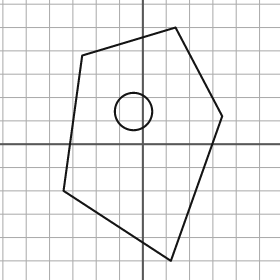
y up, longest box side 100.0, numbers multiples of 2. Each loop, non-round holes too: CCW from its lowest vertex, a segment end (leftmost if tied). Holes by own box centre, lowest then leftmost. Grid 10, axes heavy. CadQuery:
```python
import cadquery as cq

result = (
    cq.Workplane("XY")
    .moveTo(12.0, -50.0)
    .lineTo(34.0, 12.0)
    .lineTo(14.0, 50.0)
    .lineTo(-26.0, 38.0)
    .lineTo(-34.0, -20.0)
    .close()
    .moveTo(-4.0, 14.0)
    .circle(8.0)
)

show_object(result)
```